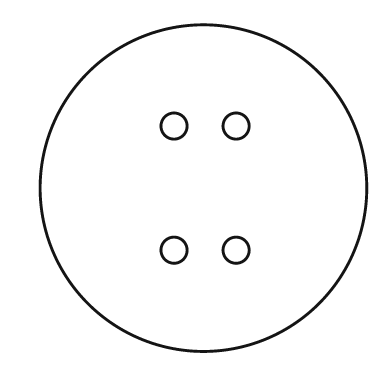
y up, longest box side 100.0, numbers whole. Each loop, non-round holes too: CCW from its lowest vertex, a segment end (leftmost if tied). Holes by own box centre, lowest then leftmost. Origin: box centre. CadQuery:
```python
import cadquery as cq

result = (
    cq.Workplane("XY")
    .moveTo(0.0, 0.0)
    .circle(50.0)
    .moveTo(-9.0, -19.0)
    .circle(4.0)
    .moveTo(10.0, -19.0)
    .circle(4.0)
    .moveTo(-9.0, 19.0)
    .circle(4.0)
    .moveTo(10.0, 19.0)
    .circle(4.0)
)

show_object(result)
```